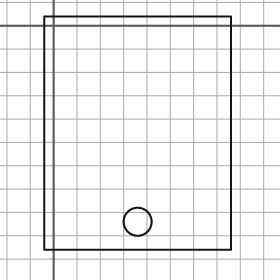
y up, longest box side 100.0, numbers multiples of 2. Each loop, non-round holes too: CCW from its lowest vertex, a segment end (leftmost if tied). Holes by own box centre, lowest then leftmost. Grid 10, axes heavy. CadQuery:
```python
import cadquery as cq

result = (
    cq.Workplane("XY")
    .moveTo(-4.0, -96.0)
    .lineTo(76.0, -96.0)
    .lineTo(76.0, 4.0)
    .lineTo(-4.0, 4.0)
    .close()
    .moveTo(36.0, -84.0)
    .circle(6.0)
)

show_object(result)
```